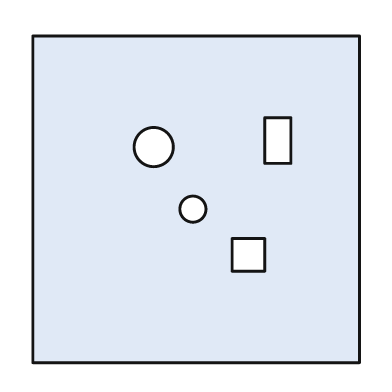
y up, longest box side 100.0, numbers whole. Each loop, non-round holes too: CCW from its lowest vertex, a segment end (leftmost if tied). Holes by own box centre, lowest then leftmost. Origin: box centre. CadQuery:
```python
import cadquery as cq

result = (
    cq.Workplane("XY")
    .moveTo(-50.0, -50.0)
    .lineTo(50.0, -50.0)
    .lineTo(50.0, 50.0)
    .lineTo(-50.0, 50.0)
    .close()
    .moveTo(11.0, -22.0)
    .lineTo(21.0, -22.0)
    .lineTo(21.0, -12.0)
    .lineTo(11.0, -12.0)
    .close()
    .moveTo(-1.0, -3.0)
    .circle(4.0)
    .moveTo(-13.0, 16.0)
    .circle(6.0)
    .moveTo(21.0, 11.0)
    .lineTo(29.0, 11.0)
    .lineTo(29.0, 25.0)
    .lineTo(21.0, 25.0)
    .close()
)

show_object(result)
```